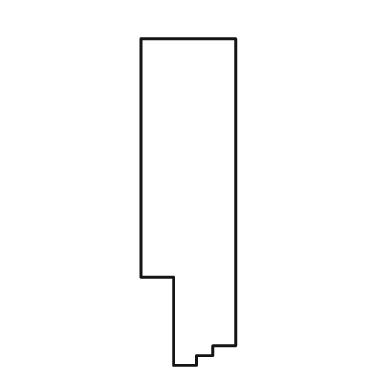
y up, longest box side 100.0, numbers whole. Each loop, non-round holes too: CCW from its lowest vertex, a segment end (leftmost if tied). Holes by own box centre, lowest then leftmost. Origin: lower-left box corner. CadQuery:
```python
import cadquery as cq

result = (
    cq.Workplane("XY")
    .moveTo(10.0, 0.0)
    .lineTo(17.0, 0.0)
    .lineTo(17.0, 3.0)
    .lineTo(22.0, 3.0)
    .lineTo(22.0, 6.0)
    .lineTo(29.0, 6.0)
    .lineTo(29.0, 100.0)
    .lineTo(0.0, 100.0)
    .lineTo(0.0, 27.0)
    .lineTo(10.0, 27.0)
    .close()
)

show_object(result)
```